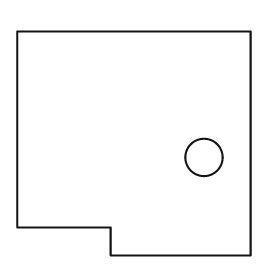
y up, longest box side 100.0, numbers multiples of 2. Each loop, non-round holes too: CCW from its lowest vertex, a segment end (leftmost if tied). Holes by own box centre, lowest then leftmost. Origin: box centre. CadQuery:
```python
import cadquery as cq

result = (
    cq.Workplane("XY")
    .moveTo(-10.0, -48.0)
    .lineTo(50.0, -48.0)
    .lineTo(50.0, 48.0)
    .lineTo(-50.0, 48.0)
    .lineTo(-50.0, -36.0)
    .lineTo(-10.0, -36.0)
    .close()
    .moveTo(30.0, -6.0)
    .circle(8.0)
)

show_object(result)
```